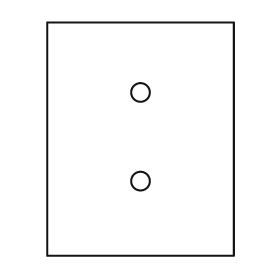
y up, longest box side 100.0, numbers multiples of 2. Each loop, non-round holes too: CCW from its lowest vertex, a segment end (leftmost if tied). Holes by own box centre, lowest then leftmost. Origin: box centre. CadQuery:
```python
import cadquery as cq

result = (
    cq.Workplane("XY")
    .moveTo(-40.0, -50.0)
    .lineTo(40.0, -50.0)
    .lineTo(40.0, 50.0)
    .lineTo(-40.0, 50.0)
    .close()
    .moveTo(0.0, -18.0)
    .circle(4.0)
    .moveTo(0.0, 20.0)
    .circle(4.0)
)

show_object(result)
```